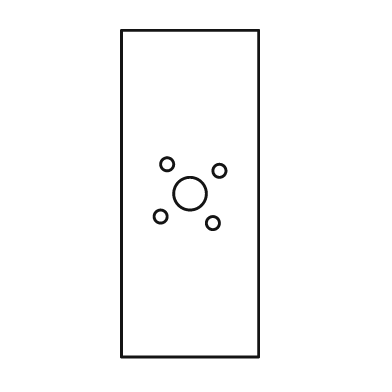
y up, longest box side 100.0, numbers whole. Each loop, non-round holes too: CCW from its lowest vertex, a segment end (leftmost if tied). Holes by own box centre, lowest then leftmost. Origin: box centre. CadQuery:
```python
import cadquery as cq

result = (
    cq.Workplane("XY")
    .moveTo(-21.0, -50.0)
    .lineTo(21.0, -50.0)
    .lineTo(21.0, 50.0)
    .lineTo(-21.0, 50.0)
    .close()
    .moveTo(7.0, -9.0)
    .circle(2.0)
    .moveTo(-9.0, -7.0)
    .circle(2.0)
    .moveTo(0.0, 0.0)
    .circle(5.0)
    .moveTo(9.0, 7.0)
    .circle(2.0)
    .moveTo(-7.0, 9.0)
    .circle(2.0)
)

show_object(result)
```